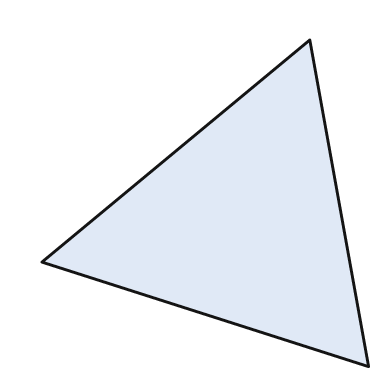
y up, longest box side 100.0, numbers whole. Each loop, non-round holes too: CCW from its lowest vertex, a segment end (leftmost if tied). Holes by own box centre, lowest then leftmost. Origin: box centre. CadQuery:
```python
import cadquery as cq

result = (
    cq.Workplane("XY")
    .moveTo(50.0, -50.0)
    .lineTo(32.0, 50.0)
    .lineTo(-50.0, -18.0)
    .close()
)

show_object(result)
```